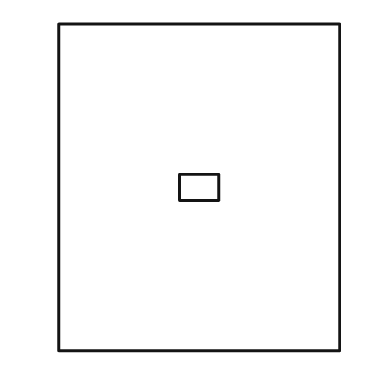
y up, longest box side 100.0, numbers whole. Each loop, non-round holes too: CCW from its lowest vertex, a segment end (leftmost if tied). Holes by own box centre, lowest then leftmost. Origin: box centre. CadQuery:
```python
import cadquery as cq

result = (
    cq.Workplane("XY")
    .moveTo(-43.0, -50.0)
    .lineTo(43.0, -50.0)
    .lineTo(43.0, 50.0)
    .lineTo(-43.0, 50.0)
    .close()
    .moveTo(-6.0, -4.0)
    .lineTo(6.0, -4.0)
    .lineTo(6.0, 4.0)
    .lineTo(-6.0, 4.0)
    .close()
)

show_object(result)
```